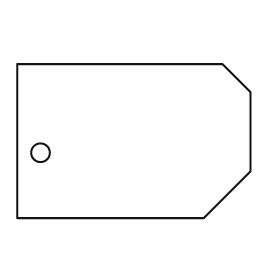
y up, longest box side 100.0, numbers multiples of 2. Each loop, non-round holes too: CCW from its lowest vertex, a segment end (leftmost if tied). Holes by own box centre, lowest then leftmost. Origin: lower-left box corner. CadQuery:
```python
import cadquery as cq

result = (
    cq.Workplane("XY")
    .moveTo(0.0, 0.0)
    .lineTo(80.0, 0.0)
    .lineTo(100.0, 20.0)
    .lineTo(100.0, 54.0)
    .lineTo(88.0, 66.0)
    .lineTo(0.0, 66.0)
    .close()
    .moveTo(10.0, 28.0)
    .circle(4.0)
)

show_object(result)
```